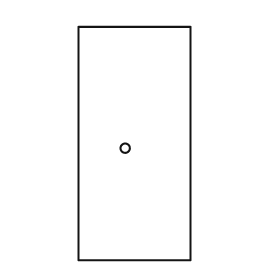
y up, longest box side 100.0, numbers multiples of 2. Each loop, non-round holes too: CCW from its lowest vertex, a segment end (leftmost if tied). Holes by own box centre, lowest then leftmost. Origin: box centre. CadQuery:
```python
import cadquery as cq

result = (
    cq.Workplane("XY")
    .moveTo(-24.0, -50.0)
    .lineTo(24.0, -50.0)
    .lineTo(24.0, 50.0)
    .lineTo(-24.0, 50.0)
    .close()
    .moveTo(-4.0, -2.0)
    .circle(2.0)
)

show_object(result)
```